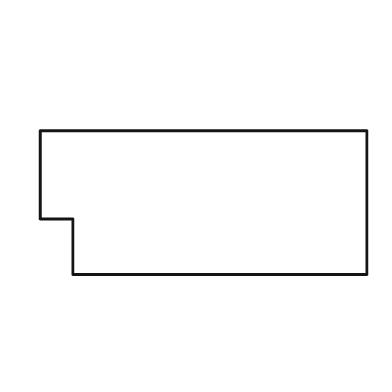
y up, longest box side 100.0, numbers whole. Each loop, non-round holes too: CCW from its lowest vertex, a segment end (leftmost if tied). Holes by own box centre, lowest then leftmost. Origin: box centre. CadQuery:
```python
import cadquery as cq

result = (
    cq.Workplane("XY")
    .moveTo(-40.0, -22.0)
    .lineTo(50.0, -22.0)
    .lineTo(50.0, 22.0)
    .lineTo(-50.0, 22.0)
    .lineTo(-50.0, -5.0)
    .lineTo(-40.0, -5.0)
    .close()
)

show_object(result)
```